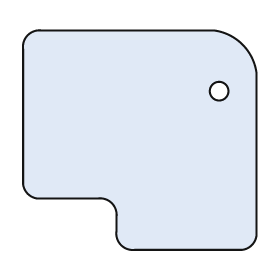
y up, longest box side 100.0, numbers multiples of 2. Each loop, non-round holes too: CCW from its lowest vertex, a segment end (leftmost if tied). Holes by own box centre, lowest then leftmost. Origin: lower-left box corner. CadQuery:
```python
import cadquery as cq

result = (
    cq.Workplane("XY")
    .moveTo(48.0, 0.0)
    .lineTo(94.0, 0.0)
    .threePointArc((98.0, 2.0), (100.0, 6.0))
    .lineTo(100.0, 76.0)
    .threePointArc((94.0, 88.0), (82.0, 94.0))
    .lineTo(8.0, 94.0)
    .threePointArc((2.0, 92.0), (0.0, 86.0))
    .lineTo(0.0, 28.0)
    .threePointArc((2.0, 24.0), (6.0, 22.0))
    .lineTo(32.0, 22.0)
    .threePointArc((38.0, 20.0), (40.0, 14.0))
    .lineTo(40.0, 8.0)
    .threePointArc((42.0, 2.0), (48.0, 0.0))
    .close()
    .moveTo(84.0, 68.0)
    .circle(4.0)
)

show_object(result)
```